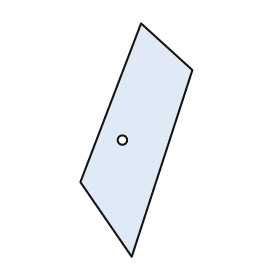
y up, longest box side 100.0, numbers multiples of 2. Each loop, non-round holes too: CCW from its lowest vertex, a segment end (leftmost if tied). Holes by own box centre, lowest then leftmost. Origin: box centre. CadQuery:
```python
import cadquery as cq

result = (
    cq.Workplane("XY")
    .moveTo(-2.0, -50.0)
    .lineTo(24.0, 30.0)
    .lineTo(2.0, 50.0)
    .lineTo(-24.0, -18.0)
    .close()
    .moveTo(-6.0, 0.0)
    .circle(2.0)
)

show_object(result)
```